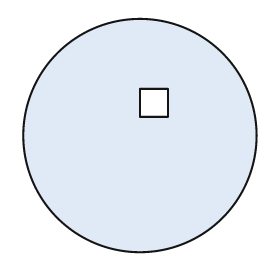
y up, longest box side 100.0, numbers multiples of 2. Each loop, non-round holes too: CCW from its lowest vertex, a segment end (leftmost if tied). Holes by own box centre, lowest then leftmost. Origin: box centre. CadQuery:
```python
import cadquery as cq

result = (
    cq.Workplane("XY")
    .moveTo(0.0, 0.0)
    .circle(50.0)
    .moveTo(0.0, 8.0)
    .lineTo(12.0, 8.0)
    .lineTo(12.0, 20.0)
    .lineTo(0.0, 20.0)
    .close()
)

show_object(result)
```